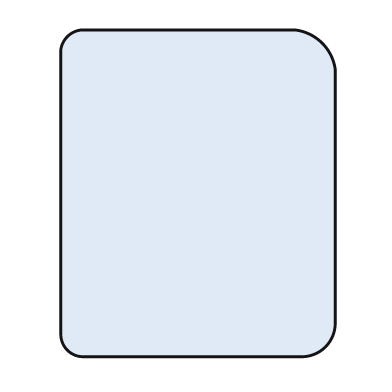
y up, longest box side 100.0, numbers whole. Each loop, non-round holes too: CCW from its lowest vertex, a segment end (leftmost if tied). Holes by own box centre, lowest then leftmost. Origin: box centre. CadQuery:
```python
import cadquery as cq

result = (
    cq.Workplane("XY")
    .moveTo(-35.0, -50.0)
    .lineTo(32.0, -50.0)
    .threePointArc((39.0, -47.0), (42.0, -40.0))
    .lineTo(42.0, 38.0)
    .threePointArc((38.0, 46.0), (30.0, 50.0))
    .lineTo(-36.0, 50.0)
    .threePointArc((-40.0, 48.0), (-42.0, 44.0))
    .lineTo(-42.0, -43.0)
    .threePointArc((-40.0, -48.0), (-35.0, -50.0))
    .close()
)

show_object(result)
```